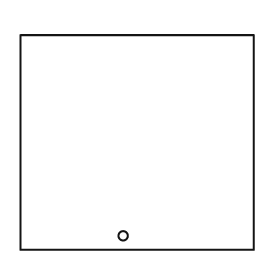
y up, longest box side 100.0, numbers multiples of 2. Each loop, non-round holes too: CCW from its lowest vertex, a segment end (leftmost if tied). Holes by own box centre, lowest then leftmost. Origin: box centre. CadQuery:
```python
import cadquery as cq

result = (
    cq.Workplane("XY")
    .moveTo(-50.0, -46.0)
    .lineTo(50.0, -46.0)
    .lineTo(50.0, 46.0)
    .lineTo(-50.0, 46.0)
    .close()
    .moveTo(-6.0, -40.0)
    .circle(2.0)
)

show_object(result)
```